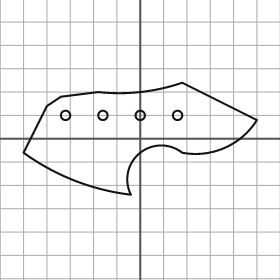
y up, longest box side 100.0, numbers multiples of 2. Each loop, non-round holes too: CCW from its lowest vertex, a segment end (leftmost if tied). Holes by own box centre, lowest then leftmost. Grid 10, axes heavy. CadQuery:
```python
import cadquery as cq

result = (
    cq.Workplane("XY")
    .moveTo(-4.0, -24.0)
    .threePointArc((0.0, -6.0), (18.0, -6.0))
    .threePointArc((36.0, -4.0), (50.0, 8.0))
    .lineTo(18.0, 24.0)
    .threePointArc((0.0, 20.0), (-18.0, 20.0))
    .lineTo(-34.0, 18.0)
    .lineTo(-40.0, 14.0)
    .lineTo(-50.0, -6.0)
    .threePointArc((-28.0, -18.0), (-4.0, -24.0))
    .close()
    .moveTo(-32.0, 10.0)
    .circle(2.0)
    .moveTo(-16.0, 10.0)
    .circle(2.0)
    .moveTo(0.0, 10.0)
    .circle(2.0)
    .moveTo(16.0, 10.0)
    .circle(2.0)
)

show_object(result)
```